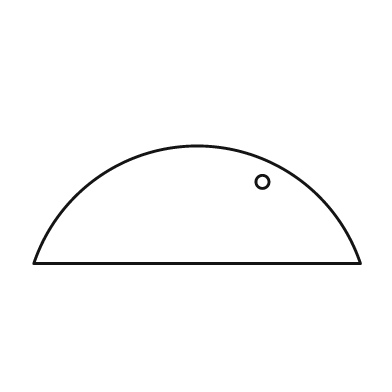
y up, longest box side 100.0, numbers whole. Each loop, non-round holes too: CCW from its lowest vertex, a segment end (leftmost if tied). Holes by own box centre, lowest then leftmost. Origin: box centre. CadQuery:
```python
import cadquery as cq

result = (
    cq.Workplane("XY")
    .moveTo(-50.0, -18.0)
    .lineTo(50.0, -18.0)
    .threePointArc((0.0, 18.0), (-50.0, -18.0))
    .close()
    .moveTo(20.0, 7.0)
    .circle(2.0)
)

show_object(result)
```